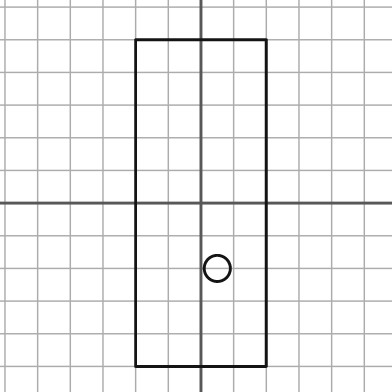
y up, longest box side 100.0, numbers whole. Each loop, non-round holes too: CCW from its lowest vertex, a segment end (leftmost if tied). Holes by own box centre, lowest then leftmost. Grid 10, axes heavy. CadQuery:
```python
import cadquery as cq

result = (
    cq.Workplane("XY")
    .moveTo(-20.0, -50.0)
    .lineTo(20.0, -50.0)
    .lineTo(20.0, 50.0)
    .lineTo(-20.0, 50.0)
    .close()
    .moveTo(5.0, -20.0)
    .circle(4.0)
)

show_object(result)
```